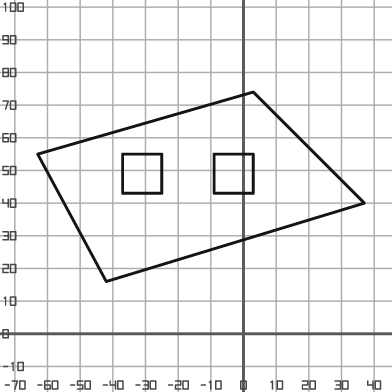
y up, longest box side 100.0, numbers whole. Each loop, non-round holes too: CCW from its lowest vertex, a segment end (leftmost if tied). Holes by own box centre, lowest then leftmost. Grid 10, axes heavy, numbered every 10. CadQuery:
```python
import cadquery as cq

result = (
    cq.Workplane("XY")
    .moveTo(-42.0, 16.0)
    .lineTo(37.0, 40.0)
    .lineTo(3.0, 74.0)
    .lineTo(-63.0, 55.0)
    .close()
    .moveTo(-37.0, 43.0)
    .lineTo(-25.0, 43.0)
    .lineTo(-25.0, 55.0)
    .lineTo(-37.0, 55.0)
    .close()
    .moveTo(-9.0, 43.0)
    .lineTo(3.0, 43.0)
    .lineTo(3.0, 55.0)
    .lineTo(-9.0, 55.0)
    .close()
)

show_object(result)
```